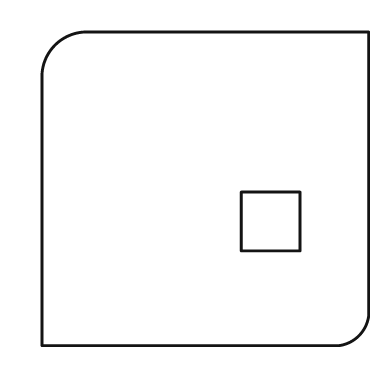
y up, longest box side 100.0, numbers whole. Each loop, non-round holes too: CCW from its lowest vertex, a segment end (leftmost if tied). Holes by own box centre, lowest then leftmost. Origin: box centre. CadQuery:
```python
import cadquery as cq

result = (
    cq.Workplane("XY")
    .moveTo(-50.0, -48.0)
    .lineTo(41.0, -48.0)
    .threePointArc((47.0, -45.0), (50.0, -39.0))
    .lineTo(50.0, 48.0)
    .lineTo(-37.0, 48.0)
    .threePointArc((-46.0, 44.0), (-50.0, 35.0))
    .close()
    .moveTo(11.0, -19.0)
    .lineTo(29.0, -19.0)
    .lineTo(29.0, -1.0)
    .lineTo(11.0, -1.0)
    .close()
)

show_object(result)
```